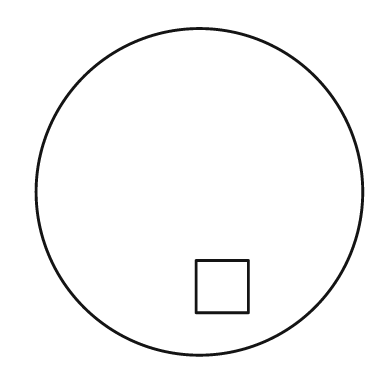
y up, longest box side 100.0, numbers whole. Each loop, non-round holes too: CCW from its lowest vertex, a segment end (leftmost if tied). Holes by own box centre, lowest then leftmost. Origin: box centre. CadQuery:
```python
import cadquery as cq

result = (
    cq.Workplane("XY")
    .moveTo(0.0, 0.0)
    .circle(50.0)
    .moveTo(-1.0, -37.0)
    .lineTo(15.0, -37.0)
    .lineTo(15.0, -21.0)
    .lineTo(-1.0, -21.0)
    .close()
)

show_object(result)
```